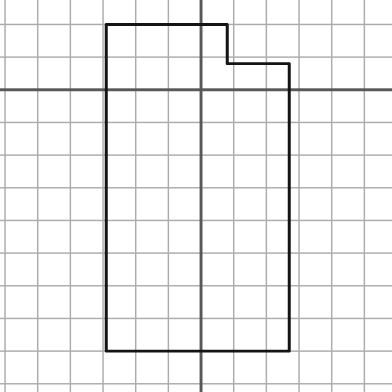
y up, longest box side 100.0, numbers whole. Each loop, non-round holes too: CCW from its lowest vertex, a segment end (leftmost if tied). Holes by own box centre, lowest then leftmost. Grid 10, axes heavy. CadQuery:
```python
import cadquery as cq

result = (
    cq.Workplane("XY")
    .moveTo(-29.0, -80.0)
    .lineTo(27.0, -80.0)
    .lineTo(27.0, 8.0)
    .lineTo(8.0, 8.0)
    .lineTo(8.0, 20.0)
    .lineTo(-29.0, 20.0)
    .close()
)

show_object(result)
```